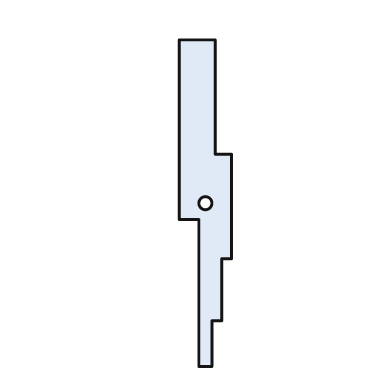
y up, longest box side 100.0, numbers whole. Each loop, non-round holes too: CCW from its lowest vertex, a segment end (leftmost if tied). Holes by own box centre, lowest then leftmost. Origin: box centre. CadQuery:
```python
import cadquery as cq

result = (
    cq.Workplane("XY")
    .moveTo(-2.0, -50.0)
    .lineTo(2.0, -50.0)
    .lineTo(2.0, -36.0)
    .lineTo(5.0, -36.0)
    .lineTo(5.0, -17.0)
    .lineTo(8.0, -17.0)
    .lineTo(8.0, 15.0)
    .lineTo(3.0, 15.0)
    .lineTo(3.0, 50.0)
    .lineTo(-8.0, 50.0)
    .lineTo(-8.0, -5.0)
    .lineTo(-2.0, -5.0)
    .close()
    .moveTo(0.0, 0.0)
    .circle(2.0)
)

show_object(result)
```